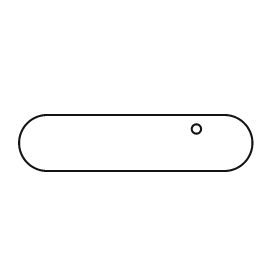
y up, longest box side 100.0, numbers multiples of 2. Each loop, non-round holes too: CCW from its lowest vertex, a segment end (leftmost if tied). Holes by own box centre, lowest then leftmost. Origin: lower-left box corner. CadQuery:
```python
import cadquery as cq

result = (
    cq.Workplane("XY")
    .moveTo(12.0, 0.0)
    .lineTo(88.0, 0.0)
    .threePointArc((100.0, 12.0), (88.0, 24.0))
    .lineTo(12.0, 24.0)
    .threePointArc((0.0, 12.0), (12.0, 0.0))
    .close()
    .moveTo(76.0, 18.0)
    .circle(2.0)
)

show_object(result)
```